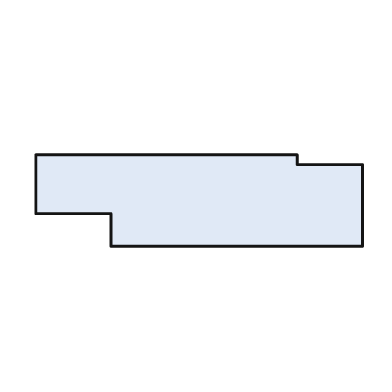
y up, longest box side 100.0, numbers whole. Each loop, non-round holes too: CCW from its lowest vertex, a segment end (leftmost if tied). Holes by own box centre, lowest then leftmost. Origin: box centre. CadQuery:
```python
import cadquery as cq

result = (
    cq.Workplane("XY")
    .moveTo(-27.0, -14.0)
    .lineTo(50.0, -14.0)
    .lineTo(50.0, 11.0)
    .lineTo(30.0, 11.0)
    .lineTo(30.0, 14.0)
    .lineTo(-50.0, 14.0)
    .lineTo(-50.0, -4.0)
    .lineTo(-27.0, -4.0)
    .close()
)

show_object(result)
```